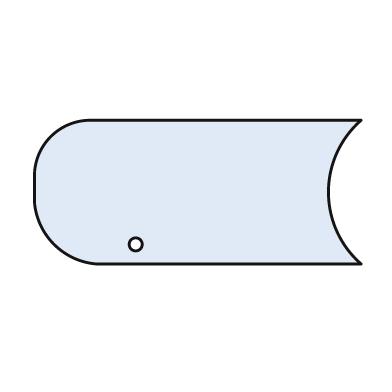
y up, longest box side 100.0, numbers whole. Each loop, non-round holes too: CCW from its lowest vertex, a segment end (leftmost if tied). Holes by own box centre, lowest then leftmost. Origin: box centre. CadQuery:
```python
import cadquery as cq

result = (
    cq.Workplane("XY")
    .moveTo(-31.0, -22.0)
    .lineTo(50.0, -22.0)
    .threePointArc((40.0, 0.0), (50.0, 22.0))
    .lineTo(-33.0, 22.0)
    .threePointArc((-45.0, 17.0), (-50.0, 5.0))
    .lineTo(-50.0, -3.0)
    .threePointArc((-44.0, -16.0), (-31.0, -22.0))
    .close()
    .moveTo(-19.0, -16.0)
    .circle(2.0)
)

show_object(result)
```